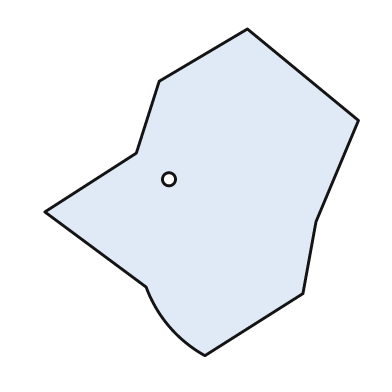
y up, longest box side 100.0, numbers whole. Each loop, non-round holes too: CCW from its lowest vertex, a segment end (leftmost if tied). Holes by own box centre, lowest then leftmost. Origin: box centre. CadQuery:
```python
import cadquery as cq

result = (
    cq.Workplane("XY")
    .moveTo(1.0, -50.0)
    .lineTo(31.0, -31.0)
    .lineTo(35.0, -9.0)
    .lineTo(48.0, 22.0)
    .lineTo(14.0, 50.0)
    .lineTo(-13.0, 34.0)
    .lineTo(-20.0, 12.0)
    .lineTo(-48.0, -6.0)
    .lineTo(-17.0, -29.0)
    .threePointArc((-10.0, -41.0), (1.0, -50.0))
    .close()
    .moveTo(-10.0, 4.0)
    .circle(2.0)
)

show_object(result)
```